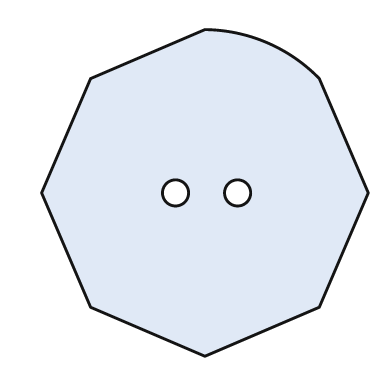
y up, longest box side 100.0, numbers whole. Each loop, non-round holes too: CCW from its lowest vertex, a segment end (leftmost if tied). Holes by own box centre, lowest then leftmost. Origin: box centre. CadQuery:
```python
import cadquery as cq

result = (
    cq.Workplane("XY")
    .moveTo(0.0, -50.0)
    .lineTo(35.0, -35.0)
    .lineTo(50.0, 0.0)
    .lineTo(35.0, 35.0)
    .threePointArc((19.0, 46.0), (0.0, 50.0))
    .lineTo(-35.0, 35.0)
    .lineTo(-50.0, 0.0)
    .lineTo(-35.0, -35.0)
    .close()
    .moveTo(-9.0, 0.0)
    .circle(4.0)
    .moveTo(10.0, 0.0)
    .circle(4.0)
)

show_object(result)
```